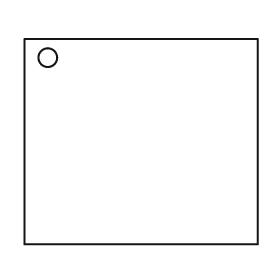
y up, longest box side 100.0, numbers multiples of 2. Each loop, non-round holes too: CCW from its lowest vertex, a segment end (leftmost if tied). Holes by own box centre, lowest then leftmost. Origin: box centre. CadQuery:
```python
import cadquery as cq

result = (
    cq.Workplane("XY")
    .moveTo(-50.0, -44.0)
    .lineTo(50.0, -44.0)
    .lineTo(50.0, 44.0)
    .lineTo(-50.0, 44.0)
    .close()
    .moveTo(-40.0, 36.0)
    .circle(4.0)
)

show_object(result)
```